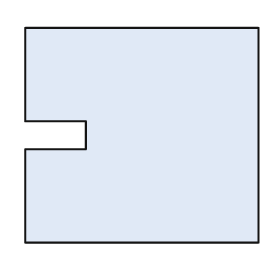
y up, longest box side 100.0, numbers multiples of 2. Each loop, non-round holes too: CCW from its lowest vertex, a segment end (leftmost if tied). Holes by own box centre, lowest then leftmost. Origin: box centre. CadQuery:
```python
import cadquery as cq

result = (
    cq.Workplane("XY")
    .moveTo(-50.0, -46.0)
    .lineTo(50.0, -46.0)
    .lineTo(50.0, 46.0)
    .lineTo(-50.0, 46.0)
    .lineTo(-50.0, 6.0)
    .lineTo(-24.0, 6.0)
    .lineTo(-24.0, -6.0)
    .lineTo(-50.0, -6.0)
    .close()
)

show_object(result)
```